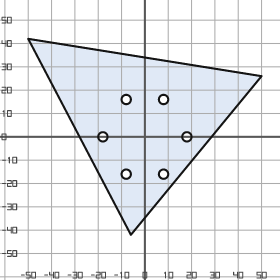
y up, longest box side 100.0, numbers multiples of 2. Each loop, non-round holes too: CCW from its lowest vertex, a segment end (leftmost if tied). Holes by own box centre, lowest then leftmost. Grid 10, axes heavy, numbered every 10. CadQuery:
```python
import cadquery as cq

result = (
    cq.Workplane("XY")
    .moveTo(-6.0, -42.0)
    .lineTo(50.0, 26.0)
    .lineTo(-50.0, 42.0)
    .close()
    .moveTo(-8.0, -16.0)
    .circle(2.0)
    .moveTo(8.0, -16.0)
    .circle(2.0)
    .moveTo(-18.0, 0.0)
    .circle(2.0)
    .moveTo(18.0, 0.0)
    .circle(2.0)
    .moveTo(-8.0, 16.0)
    .circle(2.0)
    .moveTo(8.0, 16.0)
    .circle(2.0)
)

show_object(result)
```